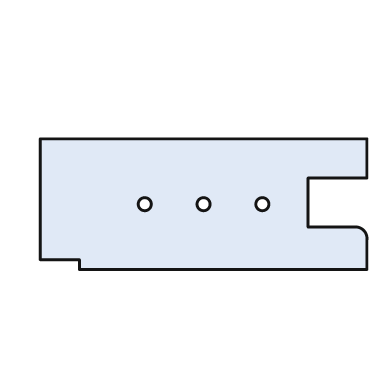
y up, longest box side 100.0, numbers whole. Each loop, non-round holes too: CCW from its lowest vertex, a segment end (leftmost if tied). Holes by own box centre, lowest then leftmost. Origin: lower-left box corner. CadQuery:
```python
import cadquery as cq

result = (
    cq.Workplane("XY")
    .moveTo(12.0, 0.0)
    .lineTo(100.0, 0.0)
    .lineTo(100.0, 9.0)
    .threePointArc((99.0, 12.0), (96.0, 13.0))
    .lineTo(82.0, 13.0)
    .lineTo(82.0, 28.0)
    .lineTo(100.0, 28.0)
    .lineTo(100.0, 40.0)
    .lineTo(0.0, 40.0)
    .lineTo(0.0, 3.0)
    .lineTo(12.0, 3.0)
    .close()
    .moveTo(32.0, 20.0)
    .circle(2.0)
    .moveTo(50.0, 20.0)
    .circle(2.0)
    .moveTo(68.0, 20.0)
    .circle(2.0)
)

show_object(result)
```